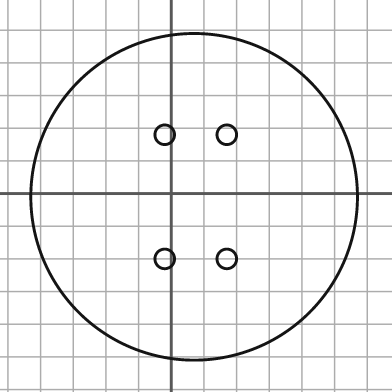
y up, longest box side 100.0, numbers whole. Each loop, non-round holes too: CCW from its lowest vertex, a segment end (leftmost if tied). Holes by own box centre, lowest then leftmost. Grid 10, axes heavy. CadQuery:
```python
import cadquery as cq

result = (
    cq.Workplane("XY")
    .moveTo(7.0, -1.0)
    .circle(50.0)
    .moveTo(-2.0, -20.0)
    .circle(3.0)
    .moveTo(17.0, -20.0)
    .circle(3.0)
    .moveTo(-2.0, 18.0)
    .circle(3.0)
    .moveTo(17.0, 18.0)
    .circle(3.0)
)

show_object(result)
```